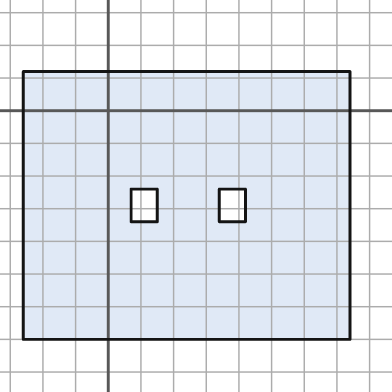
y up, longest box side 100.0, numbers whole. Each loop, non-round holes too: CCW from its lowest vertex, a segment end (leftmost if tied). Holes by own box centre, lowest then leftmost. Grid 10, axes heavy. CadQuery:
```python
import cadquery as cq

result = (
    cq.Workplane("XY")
    .moveTo(-26.0, -70.0)
    .lineTo(74.0, -70.0)
    .lineTo(74.0, 12.0)
    .lineTo(-26.0, 12.0)
    .close()
    .moveTo(7.0, -34.0)
    .lineTo(15.0, -34.0)
    .lineTo(15.0, -24.0)
    .lineTo(7.0, -24.0)
    .close()
    .moveTo(34.0, -34.0)
    .lineTo(42.0, -34.0)
    .lineTo(42.0, -24.0)
    .lineTo(34.0, -24.0)
    .close()
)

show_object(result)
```